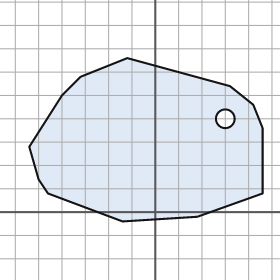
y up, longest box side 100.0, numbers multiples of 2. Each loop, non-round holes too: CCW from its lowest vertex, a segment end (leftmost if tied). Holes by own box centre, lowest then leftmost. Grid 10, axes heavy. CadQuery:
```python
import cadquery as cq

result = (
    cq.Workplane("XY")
    .moveTo(-14.0, -4.0)
    .lineTo(18.0, -2.0)
    .lineTo(46.0, 8.0)
    .lineTo(46.0, 36.0)
    .lineTo(42.0, 46.0)
    .lineTo(32.0, 54.0)
    .lineTo(-12.0, 66.0)
    .lineTo(-32.0, 58.0)
    .lineTo(-40.0, 50.0)
    .lineTo(-54.0, 28.0)
    .lineTo(-50.0, 14.0)
    .lineTo(-46.0, 8.0)
    .close()
    .moveTo(30.0, 40.0)
    .circle(4.0)
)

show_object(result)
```